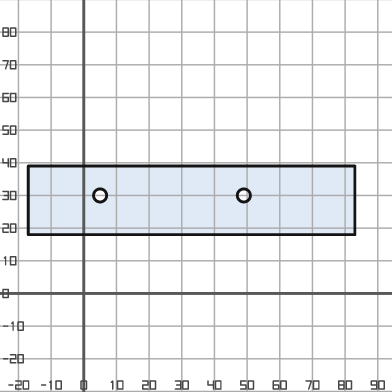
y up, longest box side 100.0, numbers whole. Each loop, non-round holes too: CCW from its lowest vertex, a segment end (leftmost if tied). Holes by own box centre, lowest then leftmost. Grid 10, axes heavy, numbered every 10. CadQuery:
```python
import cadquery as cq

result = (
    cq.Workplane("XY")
    .moveTo(-17.0, 18.0)
    .lineTo(83.0, 18.0)
    .lineTo(83.0, 39.0)
    .lineTo(-17.0, 39.0)
    .close()
    .moveTo(5.0, 30.0)
    .circle(2.0)
    .moveTo(49.0, 30.0)
    .circle(2.0)
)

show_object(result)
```